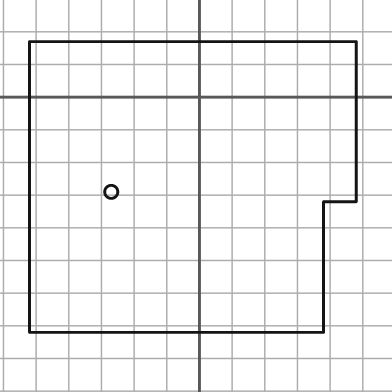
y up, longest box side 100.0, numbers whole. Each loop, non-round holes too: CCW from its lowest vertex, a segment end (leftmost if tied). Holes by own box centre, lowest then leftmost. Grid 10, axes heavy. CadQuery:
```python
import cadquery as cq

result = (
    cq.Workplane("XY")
    .moveTo(-52.0, -72.0)
    .lineTo(38.0, -72.0)
    .lineTo(38.0, -32.0)
    .lineTo(48.0, -32.0)
    .lineTo(48.0, 17.0)
    .lineTo(-52.0, 17.0)
    .close()
    .moveTo(-27.0, -29.0)
    .circle(2.0)
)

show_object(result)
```